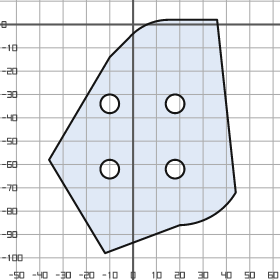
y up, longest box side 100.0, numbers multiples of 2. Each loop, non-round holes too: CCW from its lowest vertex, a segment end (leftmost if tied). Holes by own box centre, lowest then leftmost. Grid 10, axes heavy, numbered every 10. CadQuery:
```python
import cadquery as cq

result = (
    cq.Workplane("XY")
    .moveTo(-12.0, -98.0)
    .lineTo(20.0, -86.0)
    .threePointArc((34.0, -82.0), (44.0, -72.0))
    .lineTo(36.0, 2.0)
    .lineTo(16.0, 2.0)
    .threePointArc((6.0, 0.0), (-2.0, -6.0))
    .lineTo(-10.0, -14.0)
    .lineTo(-36.0, -58.0)
    .close()
    .moveTo(-10.0, -62.0)
    .circle(4.0)
    .moveTo(18.0, -62.0)
    .circle(4.0)
    .moveTo(-10.0, -34.0)
    .circle(4.0)
    .moveTo(18.0, -34.0)
    .circle(4.0)
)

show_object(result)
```